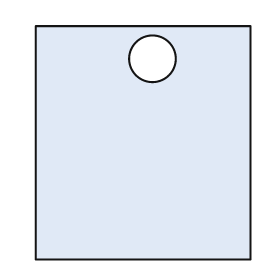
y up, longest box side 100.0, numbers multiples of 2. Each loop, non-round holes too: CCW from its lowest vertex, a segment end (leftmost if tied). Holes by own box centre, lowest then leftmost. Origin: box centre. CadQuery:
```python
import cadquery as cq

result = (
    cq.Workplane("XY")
    .moveTo(-46.0, -50.0)
    .lineTo(46.0, -50.0)
    .lineTo(46.0, 50.0)
    .lineTo(-46.0, 50.0)
    .close()
    .moveTo(4.0, 36.0)
    .circle(10.0)
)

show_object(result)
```